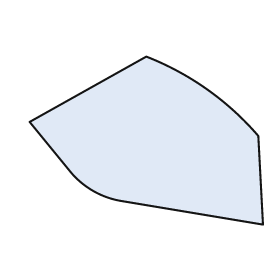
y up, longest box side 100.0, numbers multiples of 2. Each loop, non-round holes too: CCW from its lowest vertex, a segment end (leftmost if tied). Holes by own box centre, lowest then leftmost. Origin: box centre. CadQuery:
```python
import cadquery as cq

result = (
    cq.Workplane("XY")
    .moveTo(50.0, -36.0)
    .lineTo(48.0, 2.0)
    .threePointArc((26.0, 22.0), (0.0, 36.0))
    .lineTo(-50.0, 8.0)
    .lineTo(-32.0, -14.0)
    .threePointArc((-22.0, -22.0), (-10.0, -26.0))
    .close()
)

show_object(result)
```